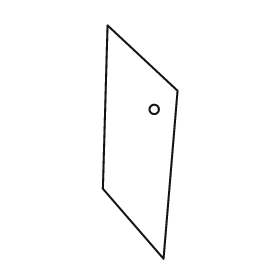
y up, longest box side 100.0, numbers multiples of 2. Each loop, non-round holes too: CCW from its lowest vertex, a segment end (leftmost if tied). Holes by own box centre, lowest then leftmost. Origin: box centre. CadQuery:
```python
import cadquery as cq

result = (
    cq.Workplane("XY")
    .moveTo(10.0, -50.0)
    .lineTo(16.0, 22.0)
    .lineTo(-14.0, 50.0)
    .lineTo(-16.0, -20.0)
    .close()
    .moveTo(6.0, 14.0)
    .circle(2.0)
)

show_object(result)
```